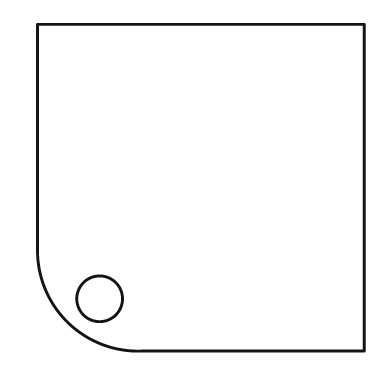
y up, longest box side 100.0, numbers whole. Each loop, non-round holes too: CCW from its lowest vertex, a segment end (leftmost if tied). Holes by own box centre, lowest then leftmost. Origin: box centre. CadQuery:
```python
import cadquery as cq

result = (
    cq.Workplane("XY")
    .moveTo(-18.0, -50.0)
    .lineTo(50.0, -50.0)
    .lineTo(50.0, 50.0)
    .lineTo(-50.0, 50.0)
    .lineTo(-50.0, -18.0)
    .threePointArc((-41.0, -41.0), (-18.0, -50.0))
    .close()
    .moveTo(-31.0, -34.0)
    .circle(7.0)
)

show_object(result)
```